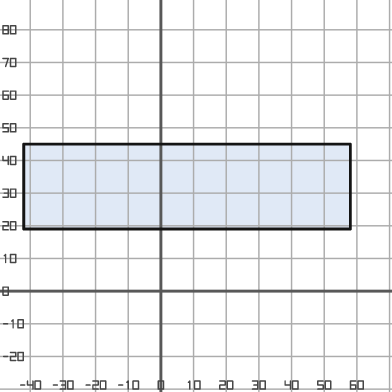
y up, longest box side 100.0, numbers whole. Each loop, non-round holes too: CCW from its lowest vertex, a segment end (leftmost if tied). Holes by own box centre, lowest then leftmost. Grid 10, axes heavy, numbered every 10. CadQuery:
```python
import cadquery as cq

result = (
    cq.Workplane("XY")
    .moveTo(-42.0, 19.0)
    .lineTo(58.0, 19.0)
    .lineTo(58.0, 45.0)
    .lineTo(-42.0, 45.0)
    .close()
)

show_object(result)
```